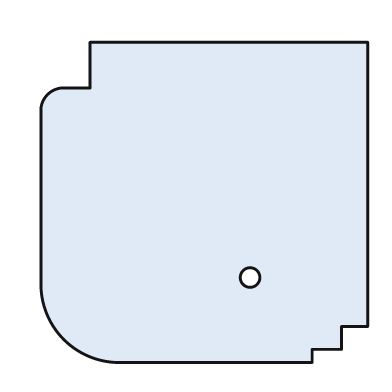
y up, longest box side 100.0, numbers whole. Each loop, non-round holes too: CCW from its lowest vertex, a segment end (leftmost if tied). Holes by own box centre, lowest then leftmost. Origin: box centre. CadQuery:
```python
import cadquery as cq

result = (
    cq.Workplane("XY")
    .moveTo(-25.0, -49.0)
    .lineTo(33.0, -49.0)
    .lineTo(33.0, -45.0)
    .lineTo(42.0, -45.0)
    .lineTo(42.0, -38.0)
    .lineTo(50.0, -38.0)
    .lineTo(50.0, 49.0)
    .lineTo(-35.0, 49.0)
    .lineTo(-35.0, 35.0)
    .lineTo(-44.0, 35.0)
    .threePointArc((-48.0, 33.0), (-50.0, 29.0))
    .lineTo(-50.0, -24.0)
    .threePointArc((-43.0, -42.0), (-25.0, -49.0))
    .close()
    .moveTo(14.0, -23.0)
    .circle(3.0)
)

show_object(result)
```